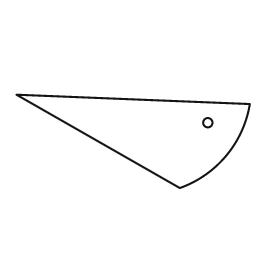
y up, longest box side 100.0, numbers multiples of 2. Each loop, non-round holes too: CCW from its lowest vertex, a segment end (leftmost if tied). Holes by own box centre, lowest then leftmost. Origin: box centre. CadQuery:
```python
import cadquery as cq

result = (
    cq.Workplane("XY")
    .moveTo(20.0, -20.0)
    .threePointArc((40.0, -6.0), (50.0, 16.0))
    .lineTo(-50.0, 20.0)
    .close()
    .moveTo(32.0, 8.0)
    .circle(2.0)
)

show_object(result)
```